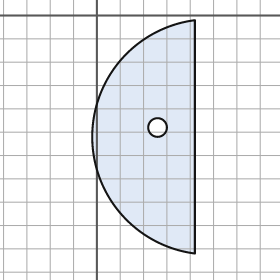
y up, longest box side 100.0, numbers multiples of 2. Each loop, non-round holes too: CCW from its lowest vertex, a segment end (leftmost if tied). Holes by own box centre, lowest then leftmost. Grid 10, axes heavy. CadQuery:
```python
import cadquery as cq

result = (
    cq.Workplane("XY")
    .moveTo(42.0, -102.0)
    .lineTo(42.0, -2.0)
    .threePointArc((-2.0, -52.0), (42.0, -102.0))
    .close()
    .moveTo(26.0, -48.0)
    .circle(4.0)
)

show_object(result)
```